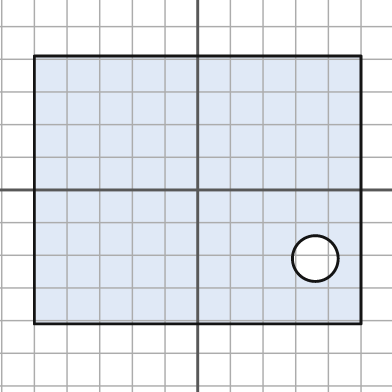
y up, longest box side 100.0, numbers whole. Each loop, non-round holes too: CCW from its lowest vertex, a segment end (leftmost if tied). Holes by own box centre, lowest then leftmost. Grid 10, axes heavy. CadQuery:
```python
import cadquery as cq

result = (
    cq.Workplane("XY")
    .moveTo(-50.0, -41.0)
    .lineTo(50.0, -41.0)
    .lineTo(50.0, 41.0)
    .lineTo(-50.0, 41.0)
    .close()
    .moveTo(36.0, -21.0)
    .circle(7.0)
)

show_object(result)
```